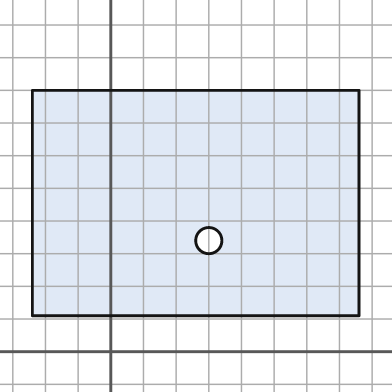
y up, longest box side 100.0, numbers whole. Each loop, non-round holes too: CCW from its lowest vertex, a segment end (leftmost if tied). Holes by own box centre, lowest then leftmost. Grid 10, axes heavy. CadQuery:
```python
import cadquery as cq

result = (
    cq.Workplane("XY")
    .moveTo(-24.0, 11.0)
    .lineTo(76.0, 11.0)
    .lineTo(76.0, 80.0)
    .lineTo(-24.0, 80.0)
    .close()
    .moveTo(30.0, 34.0)
    .circle(4.0)
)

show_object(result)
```